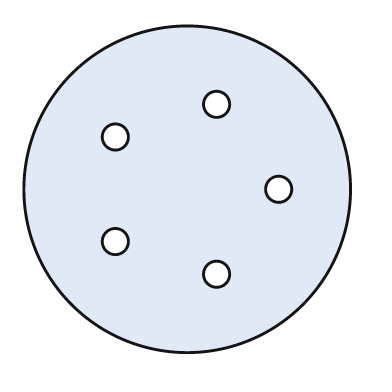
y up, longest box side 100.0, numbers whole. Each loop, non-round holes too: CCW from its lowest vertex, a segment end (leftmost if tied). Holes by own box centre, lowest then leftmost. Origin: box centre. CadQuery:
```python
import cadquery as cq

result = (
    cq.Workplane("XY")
    .moveTo(0.0, 0.0)
    .circle(50.0)
    .moveTo(9.0, -26.0)
    .circle(4.0)
    .moveTo(-22.0, -16.0)
    .circle(4.0)
    .moveTo(28.0, 0.0)
    .circle(4.0)
    .moveTo(-22.0, 16.0)
    .circle(4.0)
    .moveTo(9.0, 26.0)
    .circle(4.0)
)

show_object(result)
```